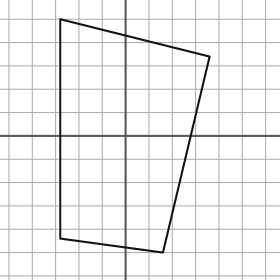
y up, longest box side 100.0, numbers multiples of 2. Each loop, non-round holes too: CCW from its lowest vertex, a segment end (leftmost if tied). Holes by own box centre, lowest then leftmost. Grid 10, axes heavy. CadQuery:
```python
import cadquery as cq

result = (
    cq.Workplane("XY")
    .moveTo(16.0, -50.0)
    .lineTo(36.0, 34.0)
    .lineTo(-28.0, 50.0)
    .lineTo(-28.0, -44.0)
    .close()
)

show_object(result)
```